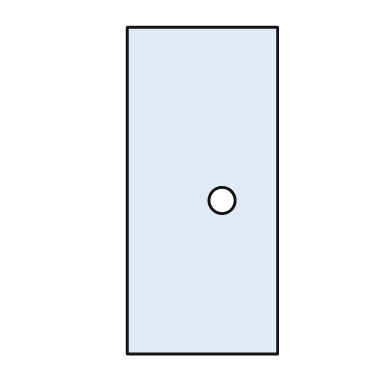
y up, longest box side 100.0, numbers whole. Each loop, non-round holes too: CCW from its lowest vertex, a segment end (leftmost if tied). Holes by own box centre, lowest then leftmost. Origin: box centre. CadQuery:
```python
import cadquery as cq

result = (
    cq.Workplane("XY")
    .moveTo(-23.0, -50.0)
    .lineTo(23.0, -50.0)
    .lineTo(23.0, 50.0)
    .lineTo(-23.0, 50.0)
    .close()
    .moveTo(6.0, -3.0)
    .circle(4.0)
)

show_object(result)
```